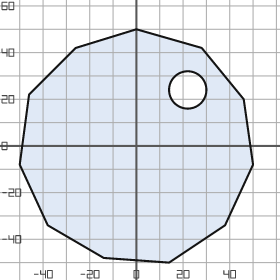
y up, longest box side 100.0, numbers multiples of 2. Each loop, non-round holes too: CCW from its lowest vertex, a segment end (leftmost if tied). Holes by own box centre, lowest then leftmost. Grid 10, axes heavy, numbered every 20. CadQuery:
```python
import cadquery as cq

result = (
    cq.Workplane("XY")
    .moveTo(14.0, -50.0)
    .lineTo(38.0, -34.0)
    .lineTo(50.0, -8.0)
    .lineTo(46.0, 20.0)
    .lineTo(28.0, 42.0)
    .lineTo(0.0, 50.0)
    .lineTo(-26.0, 42.0)
    .lineTo(-46.0, 22.0)
    .lineTo(-50.0, -8.0)
    .lineTo(-38.0, -34.0)
    .lineTo(-14.0, -48.0)
    .close()
    .moveTo(22.0, 24.0)
    .circle(8.0)
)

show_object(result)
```